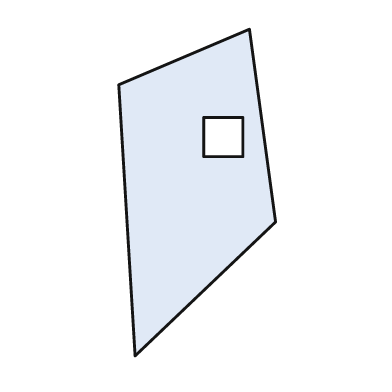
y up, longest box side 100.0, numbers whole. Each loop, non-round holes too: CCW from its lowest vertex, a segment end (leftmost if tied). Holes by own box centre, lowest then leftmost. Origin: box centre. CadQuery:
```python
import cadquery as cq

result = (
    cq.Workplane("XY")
    .moveTo(-19.0, -50.0)
    .lineTo(24.0, -9.0)
    .lineTo(16.0, 50.0)
    .lineTo(-24.0, 33.0)
    .close()
    .moveTo(2.0, 11.0)
    .lineTo(14.0, 11.0)
    .lineTo(14.0, 23.0)
    .lineTo(2.0, 23.0)
    .close()
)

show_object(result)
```